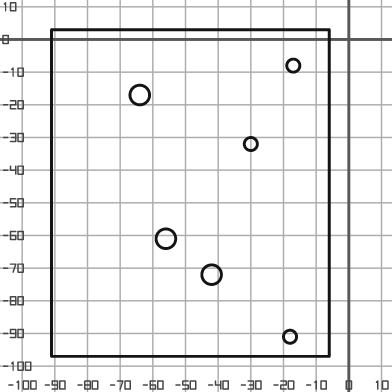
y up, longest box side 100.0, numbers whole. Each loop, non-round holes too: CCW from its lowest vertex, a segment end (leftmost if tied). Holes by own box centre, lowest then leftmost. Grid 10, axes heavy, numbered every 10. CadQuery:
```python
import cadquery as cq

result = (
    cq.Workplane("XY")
    .moveTo(-91.0, -97.0)
    .lineTo(-6.0, -97.0)
    .lineTo(-6.0, 3.0)
    .lineTo(-91.0, 3.0)
    .close()
    .moveTo(-18.0, -91.0)
    .circle(2.0)
    .moveTo(-42.0, -72.0)
    .circle(3.0)
    .moveTo(-56.0, -61.0)
    .circle(3.0)
    .moveTo(-30.0, -32.0)
    .circle(2.0)
    .moveTo(-64.0, -17.0)
    .circle(3.0)
    .moveTo(-17.0, -8.0)
    .circle(2.0)
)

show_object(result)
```